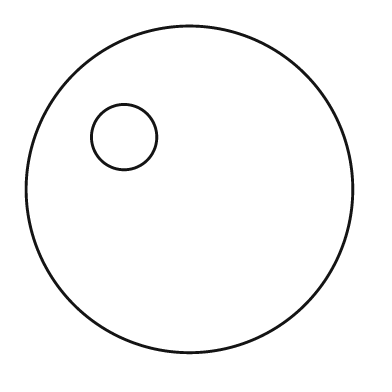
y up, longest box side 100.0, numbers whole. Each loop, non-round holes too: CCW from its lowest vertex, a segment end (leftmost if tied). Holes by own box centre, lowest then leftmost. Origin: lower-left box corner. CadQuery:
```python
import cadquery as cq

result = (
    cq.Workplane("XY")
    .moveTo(50.0, 50.0)
    .circle(50.0)
    .moveTo(30.0, 66.0)
    .circle(10.0)
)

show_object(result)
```